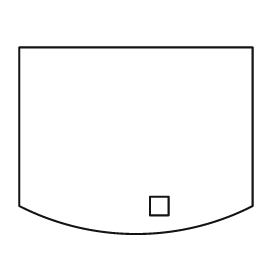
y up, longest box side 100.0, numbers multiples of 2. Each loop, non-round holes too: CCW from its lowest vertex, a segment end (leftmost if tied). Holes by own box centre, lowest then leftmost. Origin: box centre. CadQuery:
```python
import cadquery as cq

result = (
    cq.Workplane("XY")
    .moveTo(-50.0, -28.0)
    .threePointArc((0.0, -40.0), (50.0, -28.0))
    .lineTo(50.0, 40.0)
    .lineTo(-50.0, 40.0)
    .close()
    .moveTo(6.0, -32.0)
    .lineTo(14.0, -32.0)
    .lineTo(14.0, -24.0)
    .lineTo(6.0, -24.0)
    .close()
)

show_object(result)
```